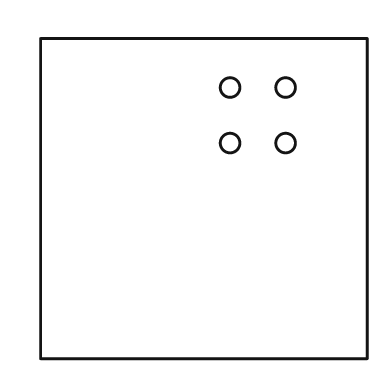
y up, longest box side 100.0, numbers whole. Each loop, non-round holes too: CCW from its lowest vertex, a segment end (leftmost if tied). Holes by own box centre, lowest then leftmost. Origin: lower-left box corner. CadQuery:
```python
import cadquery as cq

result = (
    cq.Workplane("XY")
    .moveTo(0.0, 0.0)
    .lineTo(100.0, 0.0)
    .lineTo(100.0, 98.0)
    .lineTo(0.0, 98.0)
    .close()
    .moveTo(58.0, 66.0)
    .circle(3.0)
    .moveTo(75.0, 66.0)
    .circle(3.0)
    .moveTo(58.0, 83.0)
    .circle(3.0)
    .moveTo(75.0, 83.0)
    .circle(3.0)
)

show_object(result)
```